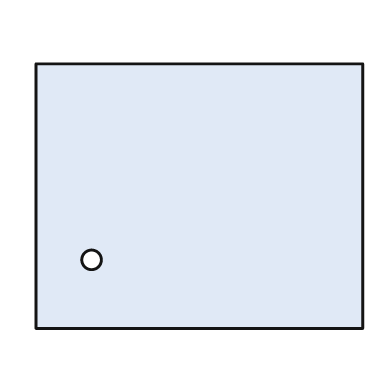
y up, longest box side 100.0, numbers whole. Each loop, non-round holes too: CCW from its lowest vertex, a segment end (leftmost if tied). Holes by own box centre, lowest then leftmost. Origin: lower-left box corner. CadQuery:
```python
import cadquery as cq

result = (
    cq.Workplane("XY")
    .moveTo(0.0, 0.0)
    .lineTo(100.0, 0.0)
    .lineTo(100.0, 81.0)
    .lineTo(0.0, 81.0)
    .close()
    .moveTo(17.0, 21.0)
    .circle(3.0)
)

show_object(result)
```